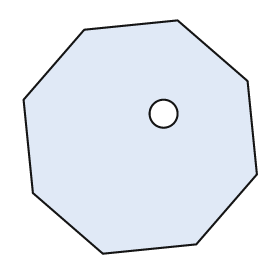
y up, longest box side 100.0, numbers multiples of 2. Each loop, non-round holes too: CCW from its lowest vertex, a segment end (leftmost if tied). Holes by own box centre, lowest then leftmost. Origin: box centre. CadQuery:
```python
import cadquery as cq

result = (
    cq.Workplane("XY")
    .moveTo(-16.0, -50.0)
    .lineTo(24.0, -46.0)
    .lineTo(50.0, -16.0)
    .lineTo(46.0, 24.0)
    .lineTo(16.0, 50.0)
    .lineTo(-24.0, 46.0)
    .lineTo(-50.0, 16.0)
    .lineTo(-46.0, -24.0)
    .close()
    .moveTo(10.0, 10.0)
    .circle(6.0)
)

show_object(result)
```